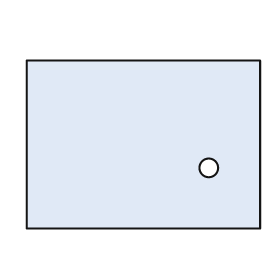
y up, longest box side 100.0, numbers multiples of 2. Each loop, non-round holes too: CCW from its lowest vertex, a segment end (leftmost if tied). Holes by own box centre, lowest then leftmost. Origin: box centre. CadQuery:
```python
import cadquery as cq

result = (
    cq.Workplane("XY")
    .moveTo(-50.0, -36.0)
    .lineTo(50.0, -36.0)
    .lineTo(50.0, 36.0)
    .lineTo(-50.0, 36.0)
    .close()
    .moveTo(28.0, -10.0)
    .circle(4.0)
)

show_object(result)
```